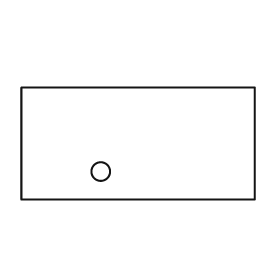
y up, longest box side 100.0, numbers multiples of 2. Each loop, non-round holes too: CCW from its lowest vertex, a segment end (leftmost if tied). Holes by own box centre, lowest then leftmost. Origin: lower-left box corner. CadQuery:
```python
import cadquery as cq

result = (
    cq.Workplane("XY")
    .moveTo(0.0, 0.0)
    .lineTo(100.0, 0.0)
    .lineTo(100.0, 48.0)
    .lineTo(0.0, 48.0)
    .close()
    .moveTo(34.0, 12.0)
    .circle(4.0)
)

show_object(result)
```